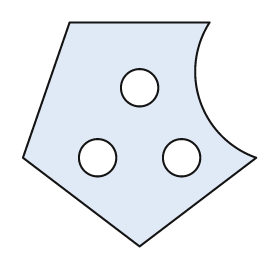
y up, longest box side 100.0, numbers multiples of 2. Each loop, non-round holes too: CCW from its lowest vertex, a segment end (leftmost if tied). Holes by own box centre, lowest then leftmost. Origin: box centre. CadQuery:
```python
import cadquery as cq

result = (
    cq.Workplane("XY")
    .moveTo(0.0, -48.0)
    .lineTo(50.0, -10.0)
    .threePointArc((26.0, 14.0), (30.0, 48.0))
    .lineTo(-30.0, 48.0)
    .lineTo(-50.0, -10.0)
    .close()
    .moveTo(-18.0, -10.0)
    .circle(8.0)
    .moveTo(18.0, -10.0)
    .circle(8.0)
    .moveTo(0.0, 20.0)
    .circle(8.0)
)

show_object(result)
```